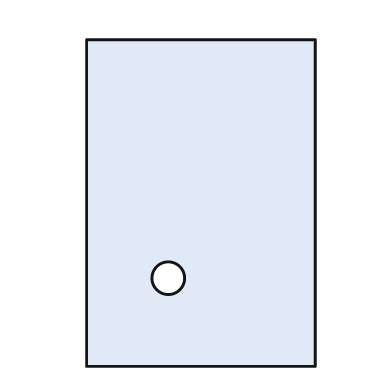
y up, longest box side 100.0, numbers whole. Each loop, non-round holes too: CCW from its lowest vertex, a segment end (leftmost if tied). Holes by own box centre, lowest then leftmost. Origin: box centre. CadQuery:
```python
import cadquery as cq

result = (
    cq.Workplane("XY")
    .moveTo(-35.0, -50.0)
    .lineTo(35.0, -50.0)
    .lineTo(35.0, 50.0)
    .lineTo(-35.0, 50.0)
    .close()
    .moveTo(-10.0, -23.0)
    .circle(5.0)
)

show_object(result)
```